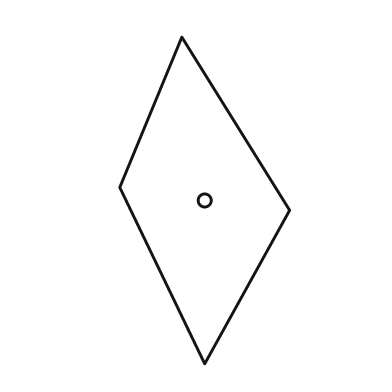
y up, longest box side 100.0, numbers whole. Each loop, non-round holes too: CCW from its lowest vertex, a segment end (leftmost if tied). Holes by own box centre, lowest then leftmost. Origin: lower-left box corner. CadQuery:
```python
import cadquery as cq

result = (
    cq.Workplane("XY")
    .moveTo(26.0, 0.0)
    .lineTo(52.0, 47.0)
    .lineTo(19.0, 100.0)
    .lineTo(0.0, 54.0)
    .close()
    .moveTo(26.0, 50.0)
    .circle(2.0)
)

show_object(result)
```